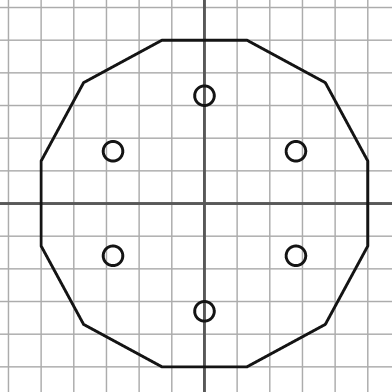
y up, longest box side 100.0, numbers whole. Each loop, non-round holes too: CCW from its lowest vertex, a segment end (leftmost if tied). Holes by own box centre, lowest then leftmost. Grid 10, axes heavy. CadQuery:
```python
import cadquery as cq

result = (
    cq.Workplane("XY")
    .moveTo(-13.0, -50.0)
    .lineTo(13.0, -50.0)
    .lineTo(37.0, -37.0)
    .lineTo(50.0, -13.0)
    .lineTo(50.0, 13.0)
    .lineTo(37.0, 37.0)
    .lineTo(13.0, 50.0)
    .lineTo(-13.0, 50.0)
    .lineTo(-37.0, 37.0)
    .lineTo(-50.0, 13.0)
    .lineTo(-50.0, -13.0)
    .lineTo(-37.0, -37.0)
    .close()
    .moveTo(0.0, -33.0)
    .circle(3.0)
    .moveTo(-28.0, -16.0)
    .circle(3.0)
    .moveTo(28.0, -16.0)
    .circle(3.0)
    .moveTo(-28.0, 16.0)
    .circle(3.0)
    .moveTo(28.0, 16.0)
    .circle(3.0)
    .moveTo(0.0, 33.0)
    .circle(3.0)
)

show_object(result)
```